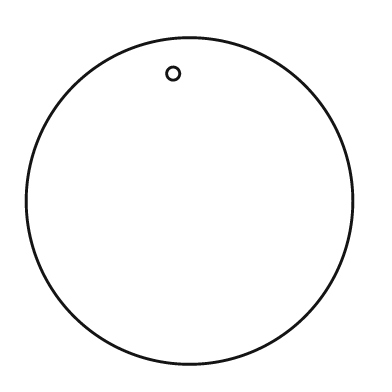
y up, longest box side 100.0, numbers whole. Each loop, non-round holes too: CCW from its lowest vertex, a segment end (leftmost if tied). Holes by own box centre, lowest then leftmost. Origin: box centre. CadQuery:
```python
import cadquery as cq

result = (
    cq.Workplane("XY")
    .moveTo(0.0, 0.0)
    .circle(50.0)
    .moveTo(-5.0, 39.0)
    .circle(2.0)
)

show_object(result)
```